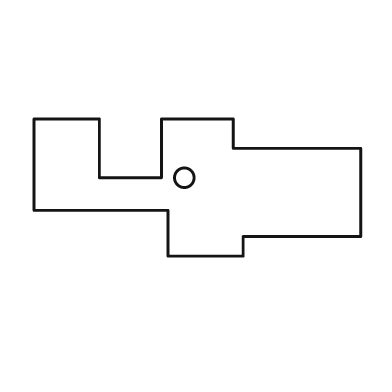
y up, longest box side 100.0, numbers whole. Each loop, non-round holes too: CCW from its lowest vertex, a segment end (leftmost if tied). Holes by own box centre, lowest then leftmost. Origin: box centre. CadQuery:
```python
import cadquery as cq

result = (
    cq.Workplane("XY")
    .moveTo(-9.0, -21.0)
    .lineTo(14.0, -21.0)
    .lineTo(14.0, -15.0)
    .lineTo(50.0, -15.0)
    .lineTo(50.0, 12.0)
    .lineTo(11.0, 12.0)
    .lineTo(11.0, 21.0)
    .lineTo(-11.0, 21.0)
    .lineTo(-11.0, 3.0)
    .lineTo(-30.0, 3.0)
    .lineTo(-30.0, 21.0)
    .lineTo(-50.0, 21.0)
    .lineTo(-50.0, -7.0)
    .lineTo(-9.0, -7.0)
    .close()
    .moveTo(-4.0, 3.0)
    .circle(3.0)
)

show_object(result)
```